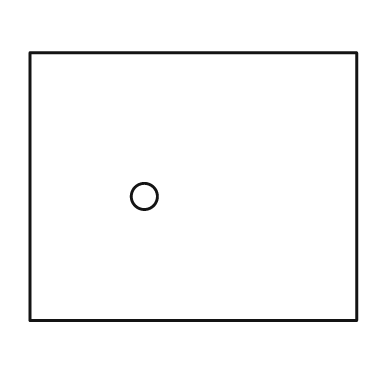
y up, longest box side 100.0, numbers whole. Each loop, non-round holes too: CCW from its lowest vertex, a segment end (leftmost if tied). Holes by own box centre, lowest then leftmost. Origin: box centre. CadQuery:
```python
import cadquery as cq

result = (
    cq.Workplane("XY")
    .moveTo(-50.0, -41.0)
    .lineTo(50.0, -41.0)
    .lineTo(50.0, 41.0)
    .lineTo(-50.0, 41.0)
    .close()
    .moveTo(-15.0, -3.0)
    .circle(4.0)
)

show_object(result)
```